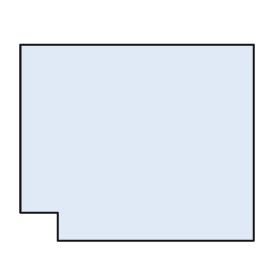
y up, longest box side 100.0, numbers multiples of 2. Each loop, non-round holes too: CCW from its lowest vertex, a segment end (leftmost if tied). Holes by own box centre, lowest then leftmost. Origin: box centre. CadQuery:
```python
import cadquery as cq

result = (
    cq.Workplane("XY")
    .moveTo(-34.0, -42.0)
    .lineTo(50.0, -42.0)
    .lineTo(50.0, 42.0)
    .lineTo(-50.0, 42.0)
    .lineTo(-50.0, -30.0)
    .lineTo(-34.0, -30.0)
    .close()
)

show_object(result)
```